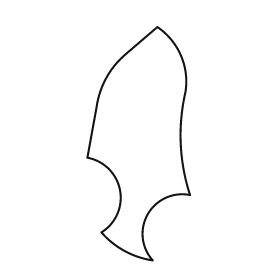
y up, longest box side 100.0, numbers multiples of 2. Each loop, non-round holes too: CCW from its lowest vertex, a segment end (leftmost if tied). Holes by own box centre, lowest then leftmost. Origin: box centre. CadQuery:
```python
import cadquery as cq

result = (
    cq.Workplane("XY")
    .moveTo(6.0, -50.0)
    .threePointArc((4.0, -30.0), (22.0, -22.0))
    .threePointArc((18.0, 0.0), (20.0, 22.0))
    .threePointArc((18.0, 38.0), (8.0, 50.0))
    .lineTo(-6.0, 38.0)
    .threePointArc((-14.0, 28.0), (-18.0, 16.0))
    .lineTo(-22.0, -6.0)
    .threePointArc((-8.0, -20.0), (-16.0, -38.0))
    .threePointArc((-6.0, -46.0), (6.0, -50.0))
    .close()
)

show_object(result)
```